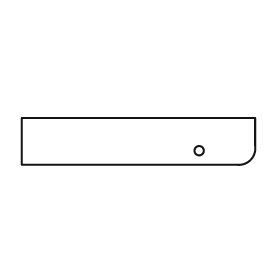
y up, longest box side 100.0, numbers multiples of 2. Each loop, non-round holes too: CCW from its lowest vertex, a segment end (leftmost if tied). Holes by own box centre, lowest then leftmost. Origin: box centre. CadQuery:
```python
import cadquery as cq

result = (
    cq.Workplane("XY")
    .moveTo(-50.0, -10.0)
    .lineTo(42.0, -10.0)
    .threePointArc((48.0, -8.0), (50.0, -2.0))
    .lineTo(50.0, 10.0)
    .lineTo(-50.0, 10.0)
    .close()
    .moveTo(26.0, -4.0)
    .circle(2.0)
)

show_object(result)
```